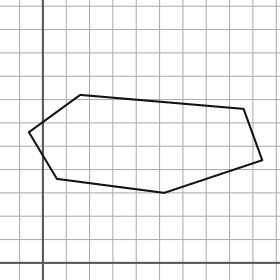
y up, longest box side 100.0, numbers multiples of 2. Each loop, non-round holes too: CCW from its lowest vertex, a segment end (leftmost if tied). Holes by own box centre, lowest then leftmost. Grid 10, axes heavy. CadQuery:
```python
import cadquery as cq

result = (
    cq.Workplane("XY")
    .moveTo(52.0, 30.0)
    .lineTo(94.0, 44.0)
    .lineTo(86.0, 66.0)
    .lineTo(16.0, 72.0)
    .lineTo(-6.0, 56.0)
    .lineTo(6.0, 36.0)
    .close()
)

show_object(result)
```